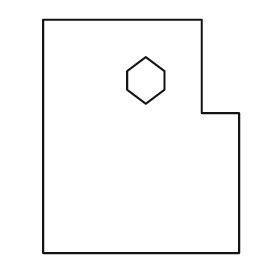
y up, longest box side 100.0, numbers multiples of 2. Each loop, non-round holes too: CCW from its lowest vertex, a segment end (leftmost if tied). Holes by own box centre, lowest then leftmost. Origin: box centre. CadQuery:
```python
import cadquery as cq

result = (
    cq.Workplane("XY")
    .moveTo(-42.0, -50.0)
    .lineTo(42.0, -50.0)
    .lineTo(42.0, 10.0)
    .lineTo(26.0, 10.0)
    .lineTo(26.0, 50.0)
    .lineTo(-42.0, 50.0)
    .close()
    .moveTo(2.0, 14.0)
    .lineTo(10.0, 20.0)
    .lineTo(10.0, 28.0)
    .lineTo(2.0, 34.0)
    .lineTo(-6.0, 28.0)
    .lineTo(-6.0, 20.0)
    .close()
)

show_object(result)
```